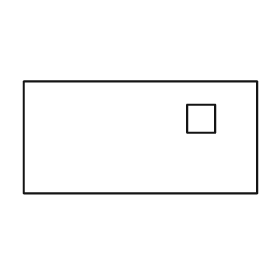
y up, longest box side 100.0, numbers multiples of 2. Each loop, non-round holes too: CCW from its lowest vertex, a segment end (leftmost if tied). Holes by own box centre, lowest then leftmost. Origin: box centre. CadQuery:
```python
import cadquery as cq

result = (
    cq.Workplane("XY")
    .moveTo(-50.0, -24.0)
    .lineTo(50.0, -24.0)
    .lineTo(50.0, 24.0)
    .lineTo(-50.0, 24.0)
    .close()
    .moveTo(20.0, 2.0)
    .lineTo(32.0, 2.0)
    .lineTo(32.0, 14.0)
    .lineTo(20.0, 14.0)
    .close()
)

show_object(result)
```